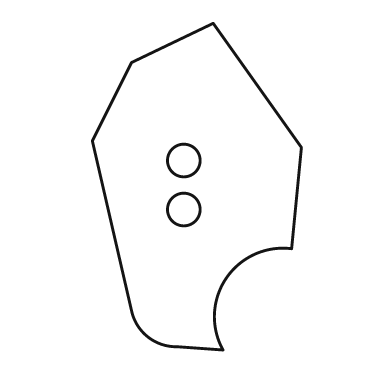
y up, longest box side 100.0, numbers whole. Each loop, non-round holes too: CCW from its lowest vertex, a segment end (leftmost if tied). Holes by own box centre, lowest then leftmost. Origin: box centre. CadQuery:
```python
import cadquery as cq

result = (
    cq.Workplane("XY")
    .moveTo(8.0, -50.0)
    .threePointArc((9.0, -28.0), (29.0, -19.0))
    .lineTo(32.0, 12.0)
    .lineTo(5.0, 50.0)
    .lineTo(-20.0, 38.0)
    .lineTo(-32.0, 14.0)
    .lineTo(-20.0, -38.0)
    .threePointArc((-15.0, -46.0), (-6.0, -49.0))
    .close()
    .moveTo(-4.0, -7.0)
    .circle(5.0)
    .moveTo(-4.0, 8.0)
    .circle(5.0)
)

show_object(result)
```